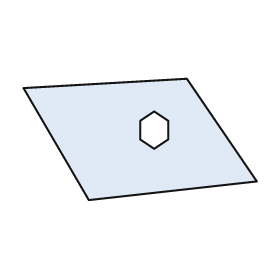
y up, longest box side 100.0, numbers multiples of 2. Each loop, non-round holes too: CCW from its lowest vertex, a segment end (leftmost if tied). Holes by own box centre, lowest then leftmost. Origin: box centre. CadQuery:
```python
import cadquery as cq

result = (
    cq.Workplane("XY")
    .moveTo(-22.0, -26.0)
    .lineTo(50.0, -18.0)
    .lineTo(20.0, 26.0)
    .lineTo(-50.0, 22.0)
    .close()
    .moveTo(6.0, -4.0)
    .lineTo(12.0, 0.0)
    .lineTo(12.0, 8.0)
    .lineTo(6.0, 12.0)
    .lineTo(0.0, 8.0)
    .lineTo(0.0, 0.0)
    .close()
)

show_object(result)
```